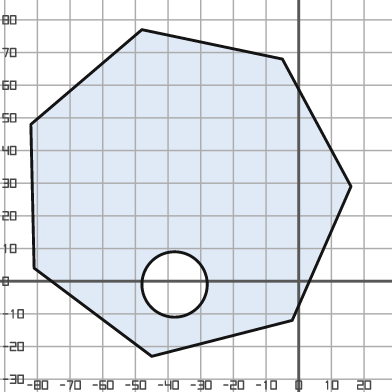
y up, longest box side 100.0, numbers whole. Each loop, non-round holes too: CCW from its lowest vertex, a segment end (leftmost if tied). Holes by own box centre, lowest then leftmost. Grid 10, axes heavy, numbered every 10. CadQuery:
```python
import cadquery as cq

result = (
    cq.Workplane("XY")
    .moveTo(-45.0, -23.0)
    .lineTo(-2.0, -12.0)
    .lineTo(16.0, 29.0)
    .lineTo(-5.0, 68.0)
    .lineTo(-48.0, 77.0)
    .lineTo(-82.0, 48.0)
    .lineTo(-81.0, 4.0)
    .close()
    .moveTo(-38.0, -1.0)
    .circle(10.0)
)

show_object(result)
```